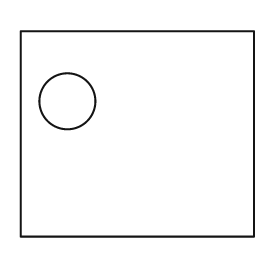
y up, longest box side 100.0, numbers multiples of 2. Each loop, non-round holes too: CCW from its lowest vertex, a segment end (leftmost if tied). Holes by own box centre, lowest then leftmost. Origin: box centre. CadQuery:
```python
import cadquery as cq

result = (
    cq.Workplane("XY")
    .moveTo(-50.0, -44.0)
    .lineTo(50.0, -44.0)
    .lineTo(50.0, 44.0)
    .lineTo(-50.0, 44.0)
    .close()
    .moveTo(-30.0, 14.0)
    .circle(12.0)
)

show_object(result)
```